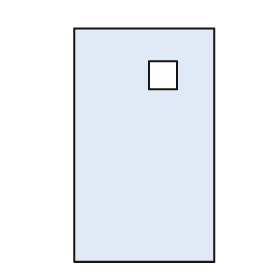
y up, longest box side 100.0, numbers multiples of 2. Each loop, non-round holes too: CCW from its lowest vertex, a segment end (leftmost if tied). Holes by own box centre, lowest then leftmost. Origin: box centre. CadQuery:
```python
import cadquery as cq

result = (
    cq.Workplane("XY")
    .moveTo(-30.0, -50.0)
    .lineTo(30.0, -50.0)
    .lineTo(30.0, 50.0)
    .lineTo(-30.0, 50.0)
    .close()
    .moveTo(2.0, 24.0)
    .lineTo(14.0, 24.0)
    .lineTo(14.0, 36.0)
    .lineTo(2.0, 36.0)
    .close()
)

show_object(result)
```